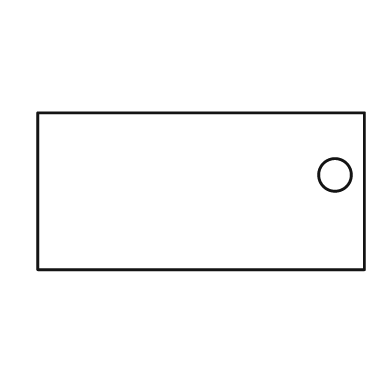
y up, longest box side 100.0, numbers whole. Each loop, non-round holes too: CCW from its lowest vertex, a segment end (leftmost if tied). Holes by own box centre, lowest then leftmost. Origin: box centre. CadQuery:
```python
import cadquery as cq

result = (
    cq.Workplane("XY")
    .moveTo(-50.0, -24.0)
    .lineTo(50.0, -24.0)
    .lineTo(50.0, 24.0)
    .lineTo(-50.0, 24.0)
    .close()
    .moveTo(41.0, 5.0)
    .circle(5.0)
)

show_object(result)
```